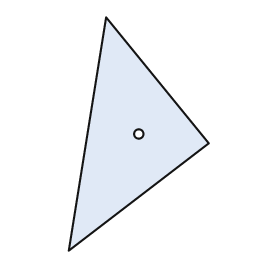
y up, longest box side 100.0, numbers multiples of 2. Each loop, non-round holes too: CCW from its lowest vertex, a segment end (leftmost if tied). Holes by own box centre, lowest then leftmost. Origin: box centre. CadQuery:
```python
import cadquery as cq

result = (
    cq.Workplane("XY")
    .moveTo(-30.0, -50.0)
    .lineTo(30.0, -4.0)
    .lineTo(-14.0, 50.0)
    .close()
    .moveTo(0.0, 0.0)
    .circle(2.0)
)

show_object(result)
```